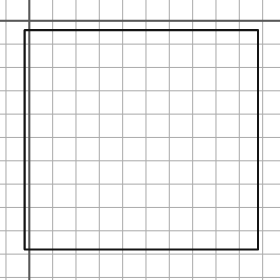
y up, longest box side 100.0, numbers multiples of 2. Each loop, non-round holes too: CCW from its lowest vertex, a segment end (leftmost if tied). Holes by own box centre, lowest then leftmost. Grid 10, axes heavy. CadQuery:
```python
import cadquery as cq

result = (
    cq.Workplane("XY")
    .moveTo(-2.0, -98.0)
    .lineTo(98.0, -98.0)
    .lineTo(98.0, -4.0)
    .lineTo(-2.0, -4.0)
    .close()
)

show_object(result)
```